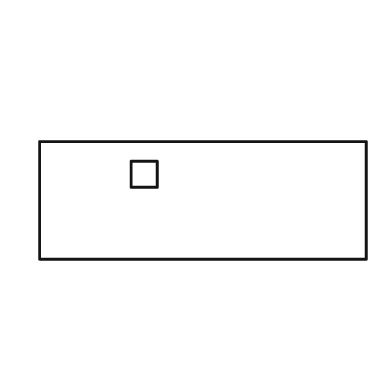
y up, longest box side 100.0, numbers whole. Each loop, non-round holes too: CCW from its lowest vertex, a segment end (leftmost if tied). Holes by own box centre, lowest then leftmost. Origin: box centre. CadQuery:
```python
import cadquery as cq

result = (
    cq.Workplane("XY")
    .moveTo(-50.0, -18.0)
    .lineTo(50.0, -18.0)
    .lineTo(50.0, 18.0)
    .lineTo(-50.0, 18.0)
    .close()
    .moveTo(-22.0, 4.0)
    .lineTo(-14.0, 4.0)
    .lineTo(-14.0, 12.0)
    .lineTo(-22.0, 12.0)
    .close()
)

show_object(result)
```